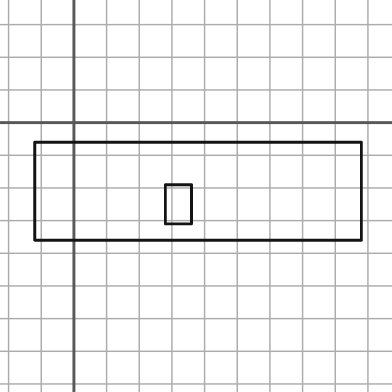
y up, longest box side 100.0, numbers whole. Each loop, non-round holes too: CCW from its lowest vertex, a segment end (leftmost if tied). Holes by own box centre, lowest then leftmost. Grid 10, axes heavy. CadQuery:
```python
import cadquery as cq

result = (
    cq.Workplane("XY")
    .moveTo(-12.0, -36.0)
    .lineTo(88.0, -36.0)
    .lineTo(88.0, -6.0)
    .lineTo(-12.0, -6.0)
    .close()
    .moveTo(28.0, -31.0)
    .lineTo(36.0, -31.0)
    .lineTo(36.0, -19.0)
    .lineTo(28.0, -19.0)
    .close()
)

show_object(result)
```